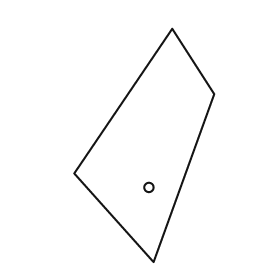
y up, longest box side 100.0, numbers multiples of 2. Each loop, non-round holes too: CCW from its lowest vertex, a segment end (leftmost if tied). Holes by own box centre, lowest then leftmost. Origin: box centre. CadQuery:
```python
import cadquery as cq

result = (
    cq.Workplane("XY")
    .moveTo(4.0, -50.0)
    .lineTo(30.0, 22.0)
    .lineTo(12.0, 50.0)
    .lineTo(-30.0, -12.0)
    .close()
    .moveTo(2.0, -18.0)
    .circle(2.0)
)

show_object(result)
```